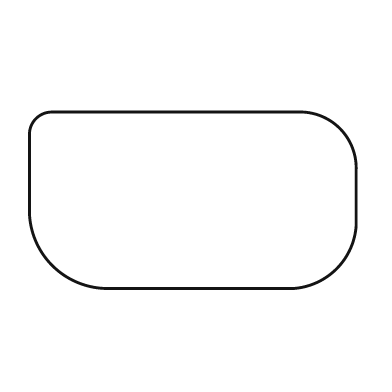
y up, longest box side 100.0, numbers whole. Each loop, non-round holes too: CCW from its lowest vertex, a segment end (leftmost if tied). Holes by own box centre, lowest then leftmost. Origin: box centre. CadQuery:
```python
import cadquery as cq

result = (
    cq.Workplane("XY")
    .moveTo(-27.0, -27.0)
    .lineTo(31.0, -27.0)
    .threePointArc((44.0, -21.0), (50.0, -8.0))
    .lineTo(50.0, 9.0)
    .threePointArc((45.0, 22.0), (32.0, 27.0))
    .lineTo(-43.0, 27.0)
    .threePointArc((-48.0, 25.0), (-50.0, 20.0))
    .lineTo(-50.0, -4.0)
    .threePointArc((-43.0, -20.0), (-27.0, -27.0))
    .close()
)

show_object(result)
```